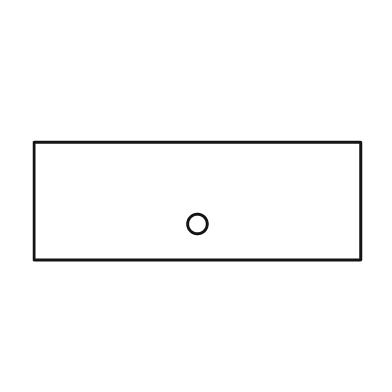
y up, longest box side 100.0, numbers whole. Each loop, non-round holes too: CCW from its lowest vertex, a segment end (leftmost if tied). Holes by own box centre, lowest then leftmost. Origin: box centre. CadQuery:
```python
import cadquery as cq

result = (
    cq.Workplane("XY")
    .moveTo(-50.0, -18.0)
    .lineTo(50.0, -18.0)
    .lineTo(50.0, 18.0)
    .lineTo(-50.0, 18.0)
    .close()
    .moveTo(0.0, -7.0)
    .circle(3.0)
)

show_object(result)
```